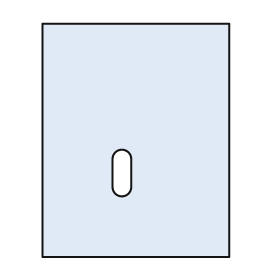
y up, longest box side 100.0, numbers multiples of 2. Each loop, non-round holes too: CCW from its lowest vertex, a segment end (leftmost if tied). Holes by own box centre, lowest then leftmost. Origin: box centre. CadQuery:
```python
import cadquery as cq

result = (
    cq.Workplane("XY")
    .moveTo(-40.0, -50.0)
    .lineTo(40.0, -50.0)
    .lineTo(40.0, 50.0)
    .lineTo(-40.0, 50.0)
    .close()
    .moveTo(-10.0, -20.0)
    .threePointArc((-6.0, -24.0), (-2.0, -20.0))
    .lineTo(-2.0, -8.0)
    .threePointArc((-6.0, -4.0), (-10.0, -8.0))
    .close()
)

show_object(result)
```